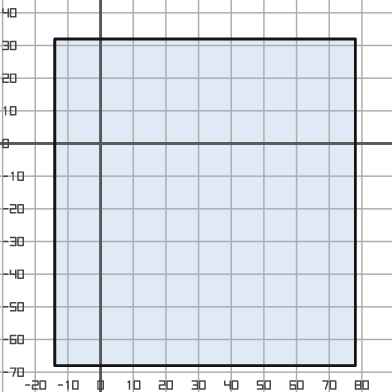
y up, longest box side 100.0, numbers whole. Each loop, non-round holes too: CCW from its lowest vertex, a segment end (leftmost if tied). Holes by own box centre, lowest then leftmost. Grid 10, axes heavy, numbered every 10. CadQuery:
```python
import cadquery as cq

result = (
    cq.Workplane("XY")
    .moveTo(-14.0, -68.0)
    .lineTo(78.0, -68.0)
    .lineTo(78.0, 32.0)
    .lineTo(-14.0, 32.0)
    .close()
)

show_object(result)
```